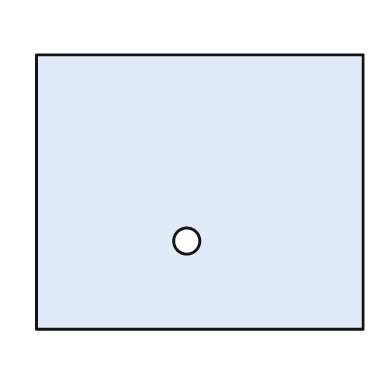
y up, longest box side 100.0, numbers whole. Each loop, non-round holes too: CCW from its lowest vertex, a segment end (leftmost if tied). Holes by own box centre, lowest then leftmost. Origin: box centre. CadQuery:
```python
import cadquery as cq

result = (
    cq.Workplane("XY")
    .moveTo(-50.0, -42.0)
    .lineTo(50.0, -42.0)
    .lineTo(50.0, 42.0)
    .lineTo(-50.0, 42.0)
    .close()
    .moveTo(-4.0, -15.0)
    .circle(4.0)
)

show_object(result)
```